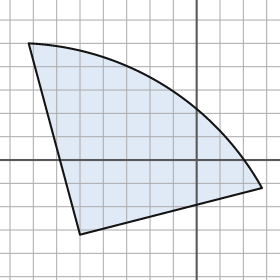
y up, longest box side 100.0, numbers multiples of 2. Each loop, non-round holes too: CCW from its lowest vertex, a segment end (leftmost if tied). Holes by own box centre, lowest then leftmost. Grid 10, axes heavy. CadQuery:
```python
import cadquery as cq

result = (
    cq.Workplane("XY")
    .moveTo(-50.0, -32.0)
    .lineTo(28.0, -12.0)
    .threePointArc((-14.0, 32.0), (-72.0, 50.0))
    .close()
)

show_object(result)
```